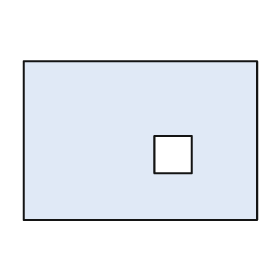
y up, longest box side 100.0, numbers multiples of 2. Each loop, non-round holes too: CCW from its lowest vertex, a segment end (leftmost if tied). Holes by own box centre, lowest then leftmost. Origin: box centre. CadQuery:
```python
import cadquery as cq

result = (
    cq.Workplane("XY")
    .moveTo(-50.0, -34.0)
    .lineTo(50.0, -34.0)
    .lineTo(50.0, 34.0)
    .lineTo(-50.0, 34.0)
    .close()
    .moveTo(6.0, -14.0)
    .lineTo(22.0, -14.0)
    .lineTo(22.0, 2.0)
    .lineTo(6.0, 2.0)
    .close()
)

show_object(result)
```